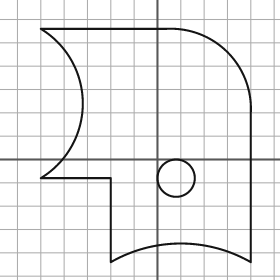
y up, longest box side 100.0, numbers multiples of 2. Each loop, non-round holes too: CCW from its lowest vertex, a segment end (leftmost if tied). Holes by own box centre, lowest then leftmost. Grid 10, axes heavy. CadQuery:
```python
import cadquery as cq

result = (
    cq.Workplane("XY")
    .moveTo(-20.0, -44.0)
    .threePointArc((10.0, -36.0), (40.0, -44.0))
    .lineTo(40.0, 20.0)
    .threePointArc((30.0, 46.0), (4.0, 56.0))
    .lineTo(-50.0, 56.0)
    .threePointArc((-32.0, 24.0), (-50.0, -8.0))
    .lineTo(-20.0, -8.0)
    .close()
    .moveTo(8.0, -8.0)
    .circle(8.0)
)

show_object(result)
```